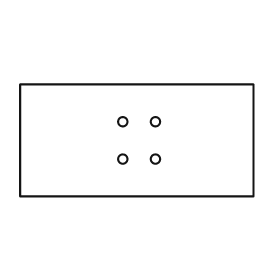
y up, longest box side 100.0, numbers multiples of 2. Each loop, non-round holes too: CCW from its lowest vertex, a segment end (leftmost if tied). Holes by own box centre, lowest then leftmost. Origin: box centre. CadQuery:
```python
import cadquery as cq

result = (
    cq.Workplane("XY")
    .moveTo(-50.0, -24.0)
    .lineTo(50.0, -24.0)
    .lineTo(50.0, 24.0)
    .lineTo(-50.0, 24.0)
    .close()
    .moveTo(-6.0, -8.0)
    .circle(2.0)
    .moveTo(8.0, -8.0)
    .circle(2.0)
    .moveTo(-6.0, 8.0)
    .circle(2.0)
    .moveTo(8.0, 8.0)
    .circle(2.0)
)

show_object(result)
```